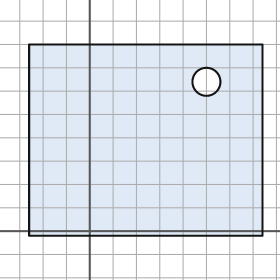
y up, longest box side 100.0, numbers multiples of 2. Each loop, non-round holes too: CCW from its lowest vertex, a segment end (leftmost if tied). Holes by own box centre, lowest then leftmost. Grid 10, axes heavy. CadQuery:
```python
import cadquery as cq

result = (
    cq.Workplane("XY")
    .moveTo(-26.0, -2.0)
    .lineTo(74.0, -2.0)
    .lineTo(74.0, 80.0)
    .lineTo(-26.0, 80.0)
    .close()
    .moveTo(50.0, 64.0)
    .circle(6.0)
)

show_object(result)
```